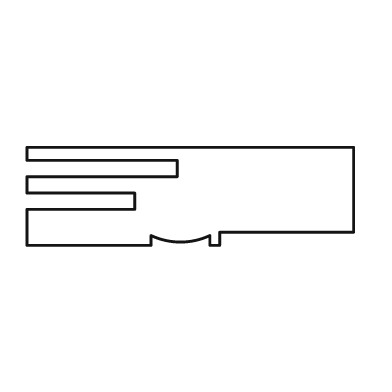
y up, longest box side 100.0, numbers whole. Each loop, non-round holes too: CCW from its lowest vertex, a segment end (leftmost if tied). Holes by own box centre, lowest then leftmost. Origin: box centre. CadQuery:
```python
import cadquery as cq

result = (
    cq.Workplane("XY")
    .moveTo(-50.0, -15.0)
    .lineTo(-12.0, -15.0)
    .lineTo(-12.0, -12.0)
    .threePointArc((-3.0, -14.0), (6.0, -12.0))
    .lineTo(6.0, -15.0)
    .lineTo(9.0, -15.0)
    .lineTo(9.0, -11.0)
    .lineTo(50.0, -11.0)
    .lineTo(50.0, 15.0)
    .lineTo(-50.0, 15.0)
    .lineTo(-50.0, 11.0)
    .lineTo(-4.0, 11.0)
    .lineTo(-4.0, 6.0)
    .lineTo(-50.0, 6.0)
    .lineTo(-50.0, 1.0)
    .lineTo(-17.0, 1.0)
    .lineTo(-17.0, -4.0)
    .lineTo(-50.0, -4.0)
    .close()
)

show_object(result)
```